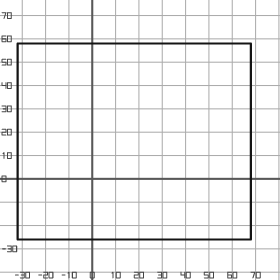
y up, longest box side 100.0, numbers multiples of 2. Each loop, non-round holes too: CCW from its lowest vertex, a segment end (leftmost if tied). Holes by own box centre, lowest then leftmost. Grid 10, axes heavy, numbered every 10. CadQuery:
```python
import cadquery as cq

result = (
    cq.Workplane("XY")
    .moveTo(-32.0, -26.0)
    .lineTo(68.0, -26.0)
    .lineTo(68.0, 58.0)
    .lineTo(-32.0, 58.0)
    .close()
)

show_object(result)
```